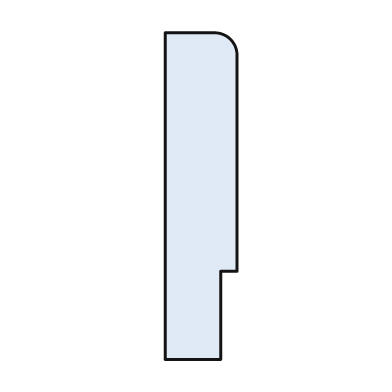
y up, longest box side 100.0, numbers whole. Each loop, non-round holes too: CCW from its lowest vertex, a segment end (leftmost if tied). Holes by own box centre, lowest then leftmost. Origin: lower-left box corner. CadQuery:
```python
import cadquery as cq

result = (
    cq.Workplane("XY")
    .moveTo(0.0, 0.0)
    .lineTo(17.0, 0.0)
    .lineTo(17.0, 27.0)
    .lineTo(22.0, 27.0)
    .lineTo(22.0, 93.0)
    .threePointArc((20.0, 98.0), (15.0, 100.0))
    .lineTo(0.0, 100.0)
    .close()
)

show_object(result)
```